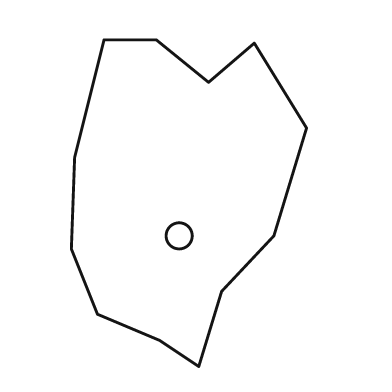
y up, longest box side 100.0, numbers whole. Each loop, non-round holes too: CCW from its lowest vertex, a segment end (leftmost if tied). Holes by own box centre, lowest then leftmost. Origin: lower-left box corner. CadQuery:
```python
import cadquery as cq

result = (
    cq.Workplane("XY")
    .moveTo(39.0, 0.0)
    .lineTo(46.0, 23.0)
    .lineTo(62.0, 40.0)
    .lineTo(72.0, 73.0)
    .lineTo(56.0, 99.0)
    .lineTo(42.0, 87.0)
    .lineTo(26.0, 100.0)
    .lineTo(10.0, 100.0)
    .lineTo(1.0, 64.0)
    .lineTo(0.0, 36.0)
    .lineTo(8.0, 16.0)
    .lineTo(27.0, 8.0)
    .close()
    .moveTo(33.0, 40.0)
    .circle(4.0)
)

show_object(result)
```